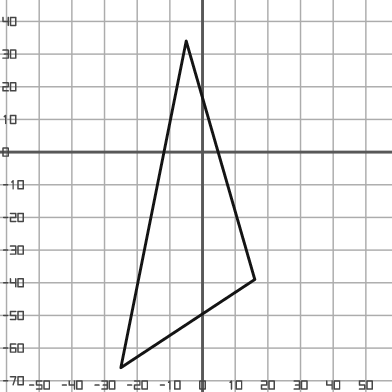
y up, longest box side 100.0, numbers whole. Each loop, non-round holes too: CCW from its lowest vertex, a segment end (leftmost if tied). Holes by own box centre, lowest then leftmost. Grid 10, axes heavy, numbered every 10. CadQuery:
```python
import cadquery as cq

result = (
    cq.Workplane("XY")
    .moveTo(-25.0, -66.0)
    .lineTo(16.0, -39.0)
    .lineTo(-5.0, 34.0)
    .close()
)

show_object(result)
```